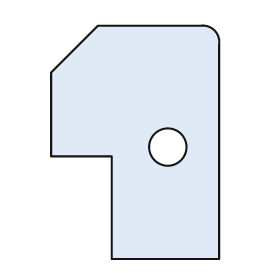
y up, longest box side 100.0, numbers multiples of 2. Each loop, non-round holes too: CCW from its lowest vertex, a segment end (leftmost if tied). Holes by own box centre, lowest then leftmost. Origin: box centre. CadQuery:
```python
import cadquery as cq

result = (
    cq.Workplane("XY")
    .moveTo(-10.0, -50.0)
    .lineTo(36.0, -50.0)
    .lineTo(36.0, 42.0)
    .threePointArc((34.0, 48.0), (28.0, 50.0))
    .lineTo(-16.0, 50.0)
    .lineTo(-36.0, 30.0)
    .lineTo(-36.0, -6.0)
    .lineTo(-10.0, -6.0)
    .close()
    .moveTo(14.0, -2.0)
    .circle(8.0)
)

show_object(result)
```